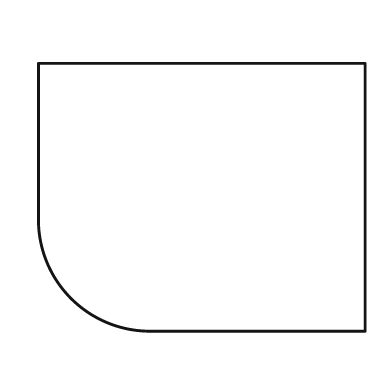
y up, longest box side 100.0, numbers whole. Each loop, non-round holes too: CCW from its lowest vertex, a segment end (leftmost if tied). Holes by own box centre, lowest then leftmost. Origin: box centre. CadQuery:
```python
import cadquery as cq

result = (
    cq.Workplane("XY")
    .moveTo(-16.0, -41.0)
    .lineTo(50.0, -41.0)
    .lineTo(50.0, 41.0)
    .lineTo(-50.0, 41.0)
    .lineTo(-50.0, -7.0)
    .threePointArc((-40.0, -31.0), (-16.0, -41.0))
    .close()
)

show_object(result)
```